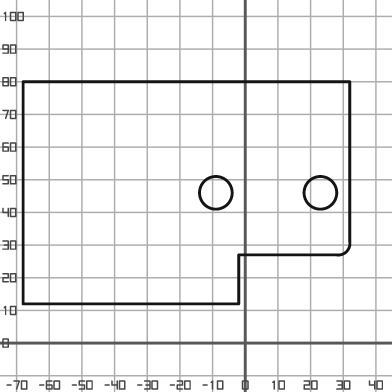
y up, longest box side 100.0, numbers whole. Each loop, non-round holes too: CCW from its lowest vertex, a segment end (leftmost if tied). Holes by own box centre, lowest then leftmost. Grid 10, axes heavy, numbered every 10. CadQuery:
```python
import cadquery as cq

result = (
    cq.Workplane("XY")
    .moveTo(-68.0, 12.0)
    .lineTo(-2.0, 12.0)
    .lineTo(-2.0, 27.0)
    .lineTo(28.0, 27.0)
    .threePointArc((31.0, 28.0), (32.0, 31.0))
    .lineTo(32.0, 80.0)
    .lineTo(-68.0, 80.0)
    .close()
    .moveTo(-9.0, 46.0)
    .circle(5.0)
    .moveTo(23.0, 46.0)
    .circle(5.0)
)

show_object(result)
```